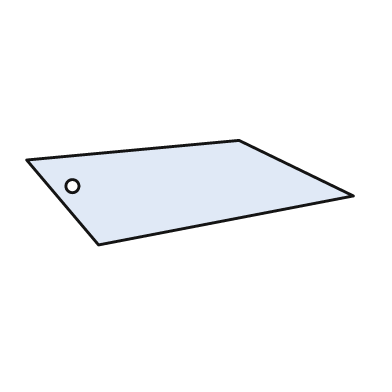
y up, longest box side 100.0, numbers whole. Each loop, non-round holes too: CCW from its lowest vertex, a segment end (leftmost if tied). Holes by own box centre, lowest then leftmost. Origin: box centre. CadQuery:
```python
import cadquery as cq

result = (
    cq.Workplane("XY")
    .moveTo(-28.0, -16.0)
    .lineTo(50.0, -1.0)
    .lineTo(15.0, 16.0)
    .lineTo(-50.0, 10.0)
    .close()
    .moveTo(-36.0, 2.0)
    .circle(2.0)
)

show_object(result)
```